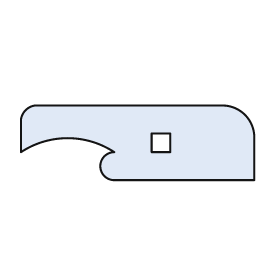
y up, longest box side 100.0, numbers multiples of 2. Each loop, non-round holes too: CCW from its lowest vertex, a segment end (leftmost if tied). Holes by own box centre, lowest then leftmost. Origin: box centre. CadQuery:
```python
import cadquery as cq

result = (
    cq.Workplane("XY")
    .moveTo(-10.0, -16.0)
    .lineTo(50.0, -16.0)
    .lineTo(50.0, 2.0)
    .threePointArc((46.0, 12.0), (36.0, 16.0))
    .lineTo(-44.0, 16.0)
    .threePointArc((-48.0, 14.0), (-50.0, 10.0))
    .lineTo(-50.0, -4.0)
    .threePointArc((-30.0, 2.0), (-10.0, -4.0))
    .threePointArc((-16.0, -10.0), (-10.0, -16.0))
    .close()
    .moveTo(6.0, -4.0)
    .lineTo(14.0, -4.0)
    .lineTo(14.0, 4.0)
    .lineTo(6.0, 4.0)
    .close()
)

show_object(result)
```